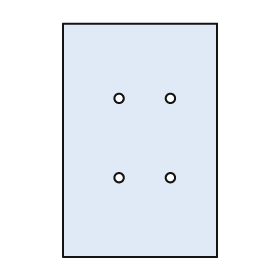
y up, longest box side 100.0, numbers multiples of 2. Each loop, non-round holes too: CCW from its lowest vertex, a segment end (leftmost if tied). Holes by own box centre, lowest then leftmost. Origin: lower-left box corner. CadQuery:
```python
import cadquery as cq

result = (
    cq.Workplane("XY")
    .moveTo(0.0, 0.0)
    .lineTo(66.0, 0.0)
    .lineTo(66.0, 100.0)
    .lineTo(0.0, 100.0)
    .close()
    .moveTo(24.0, 34.0)
    .circle(2.0)
    .moveTo(46.0, 34.0)
    .circle(2.0)
    .moveTo(24.0, 68.0)
    .circle(2.0)
    .moveTo(46.0, 68.0)
    .circle(2.0)
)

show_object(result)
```